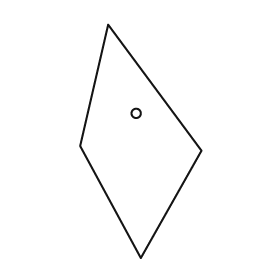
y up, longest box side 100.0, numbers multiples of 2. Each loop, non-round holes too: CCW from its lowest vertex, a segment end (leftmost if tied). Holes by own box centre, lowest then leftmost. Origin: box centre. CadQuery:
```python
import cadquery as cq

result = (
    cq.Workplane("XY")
    .moveTo(0.0, -50.0)
    .lineTo(26.0, -4.0)
    .lineTo(-14.0, 50.0)
    .lineTo(-26.0, -2.0)
    .close()
    .moveTo(-2.0, 12.0)
    .circle(2.0)
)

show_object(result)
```